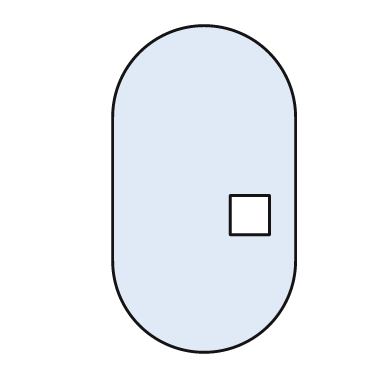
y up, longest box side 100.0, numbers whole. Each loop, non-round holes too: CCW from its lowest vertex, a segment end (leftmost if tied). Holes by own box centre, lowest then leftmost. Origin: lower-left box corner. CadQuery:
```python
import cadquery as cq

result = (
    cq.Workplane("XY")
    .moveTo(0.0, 28.0)
    .threePointArc((28.0, 0.0), (56.0, 28.0))
    .lineTo(56.0, 72.0)
    .threePointArc((28.0, 100.0), (0.0, 72.0))
    .close()
    .moveTo(36.0, 36.0)
    .lineTo(48.0, 36.0)
    .lineTo(48.0, 48.0)
    .lineTo(36.0, 48.0)
    .close()
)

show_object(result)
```